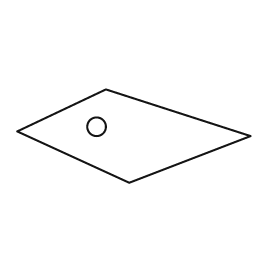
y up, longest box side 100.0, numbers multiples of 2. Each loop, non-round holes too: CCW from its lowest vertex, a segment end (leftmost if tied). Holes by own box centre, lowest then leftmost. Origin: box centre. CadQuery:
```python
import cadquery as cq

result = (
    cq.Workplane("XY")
    .moveTo(-2.0, -20.0)
    .lineTo(50.0, 0.0)
    .lineTo(-12.0, 20.0)
    .lineTo(-50.0, 2.0)
    .close()
    .moveTo(-16.0, 4.0)
    .circle(4.0)
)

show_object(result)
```